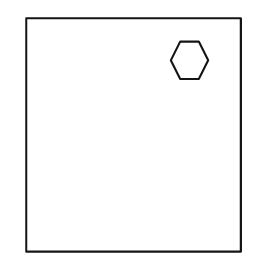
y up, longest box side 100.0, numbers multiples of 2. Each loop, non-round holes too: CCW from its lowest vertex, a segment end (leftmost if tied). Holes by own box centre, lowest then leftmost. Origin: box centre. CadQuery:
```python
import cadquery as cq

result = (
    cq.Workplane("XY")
    .moveTo(-46.0, -50.0)
    .lineTo(46.0, -50.0)
    .lineTo(46.0, 50.0)
    .lineTo(-46.0, 50.0)
    .close()
    .moveTo(20.0, 24.0)
    .lineTo(28.0, 24.0)
    .lineTo(32.0, 32.0)
    .lineTo(28.0, 40.0)
    .lineTo(20.0, 40.0)
    .lineTo(16.0, 32.0)
    .close()
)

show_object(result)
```